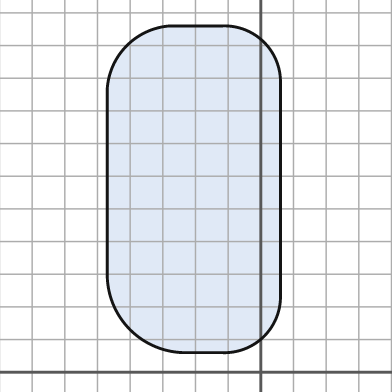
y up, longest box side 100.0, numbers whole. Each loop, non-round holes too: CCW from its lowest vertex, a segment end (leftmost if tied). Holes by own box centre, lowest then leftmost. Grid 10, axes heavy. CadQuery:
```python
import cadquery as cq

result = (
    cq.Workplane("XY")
    .moveTo(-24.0, 6.0)
    .lineTo(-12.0, 6.0)
    .threePointArc((1.0, 11.0), (6.0, 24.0))
    .lineTo(6.0, 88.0)
    .threePointArc((1.0, 101.0), (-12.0, 106.0))
    .lineTo(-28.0, 106.0)
    .threePointArc((-41.0, 100.0), (-47.0, 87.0))
    .lineTo(-47.0, 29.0)
    .threePointArc((-40.0, 13.0), (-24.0, 6.0))
    .close()
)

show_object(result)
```